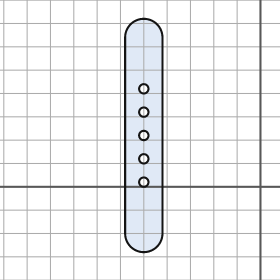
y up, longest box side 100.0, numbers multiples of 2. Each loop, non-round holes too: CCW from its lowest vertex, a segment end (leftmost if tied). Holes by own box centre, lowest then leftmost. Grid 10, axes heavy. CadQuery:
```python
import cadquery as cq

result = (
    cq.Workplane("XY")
    .moveTo(-58.0, -20.0)
    .threePointArc((-50.0, -28.0), (-42.0, -20.0))
    .lineTo(-42.0, 64.0)
    .threePointArc((-50.0, 72.0), (-58.0, 64.0))
    .close()
    .moveTo(-50.0, 2.0)
    .circle(2.0)
    .moveTo(-50.0, 12.0)
    .circle(2.0)
    .moveTo(-50.0, 22.0)
    .circle(2.0)
    .moveTo(-50.0, 32.0)
    .circle(2.0)
    .moveTo(-50.0, 42.0)
    .circle(2.0)
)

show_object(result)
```